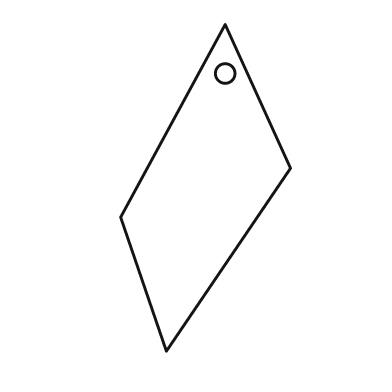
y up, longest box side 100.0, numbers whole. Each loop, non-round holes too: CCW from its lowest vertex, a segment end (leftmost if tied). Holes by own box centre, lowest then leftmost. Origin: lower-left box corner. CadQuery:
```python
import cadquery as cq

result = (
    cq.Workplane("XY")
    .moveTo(14.0, 0.0)
    .lineTo(52.0, 56.0)
    .lineTo(32.0, 100.0)
    .lineTo(0.0, 41.0)
    .close()
    .moveTo(32.0, 85.0)
    .circle(3.0)
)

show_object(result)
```